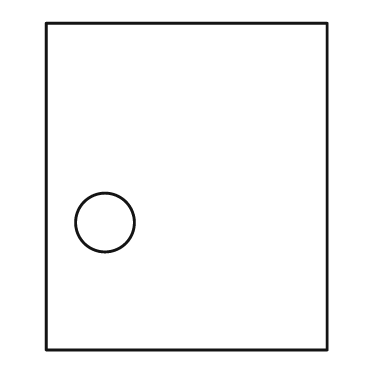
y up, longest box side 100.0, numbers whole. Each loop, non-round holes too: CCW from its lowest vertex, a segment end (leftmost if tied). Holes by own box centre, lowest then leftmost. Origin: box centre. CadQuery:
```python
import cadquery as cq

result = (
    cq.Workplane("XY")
    .moveTo(-43.0, -50.0)
    .lineTo(43.0, -50.0)
    .lineTo(43.0, 50.0)
    .lineTo(-43.0, 50.0)
    .close()
    .moveTo(-25.0, -11.0)
    .circle(9.0)
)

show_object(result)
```